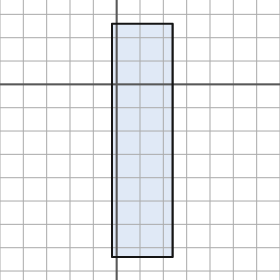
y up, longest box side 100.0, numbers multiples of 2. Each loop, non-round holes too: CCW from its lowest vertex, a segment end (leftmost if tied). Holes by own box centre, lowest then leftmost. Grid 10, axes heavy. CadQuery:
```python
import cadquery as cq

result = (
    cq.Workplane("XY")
    .moveTo(-2.0, -74.0)
    .lineTo(24.0, -74.0)
    .lineTo(24.0, 26.0)
    .lineTo(-2.0, 26.0)
    .close()
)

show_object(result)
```